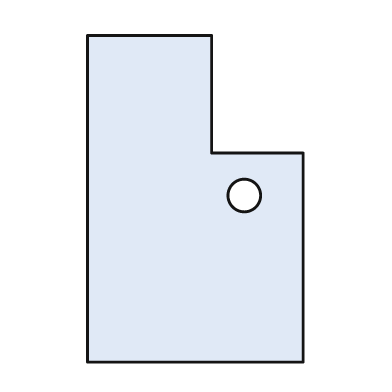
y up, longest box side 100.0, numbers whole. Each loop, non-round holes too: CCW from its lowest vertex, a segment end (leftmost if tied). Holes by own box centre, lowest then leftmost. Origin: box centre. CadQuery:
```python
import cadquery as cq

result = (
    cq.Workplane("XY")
    .moveTo(-33.0, -50.0)
    .lineTo(33.0, -50.0)
    .lineTo(33.0, 14.0)
    .lineTo(5.0, 14.0)
    .lineTo(5.0, 50.0)
    .lineTo(-33.0, 50.0)
    .close()
    .moveTo(15.0, 1.0)
    .circle(5.0)
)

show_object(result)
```